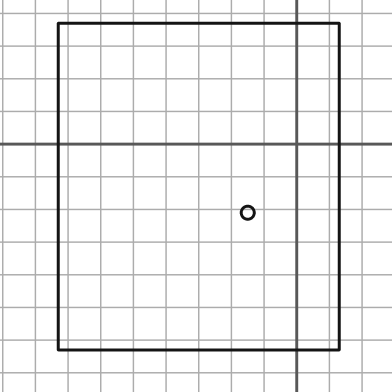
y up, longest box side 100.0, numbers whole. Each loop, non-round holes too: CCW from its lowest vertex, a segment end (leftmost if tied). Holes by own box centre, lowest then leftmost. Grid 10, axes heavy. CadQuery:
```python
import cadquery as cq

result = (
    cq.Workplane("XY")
    .moveTo(-73.0, -63.0)
    .lineTo(13.0, -63.0)
    .lineTo(13.0, 37.0)
    .lineTo(-73.0, 37.0)
    .close()
    .moveTo(-15.0, -21.0)
    .circle(2.0)
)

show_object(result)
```